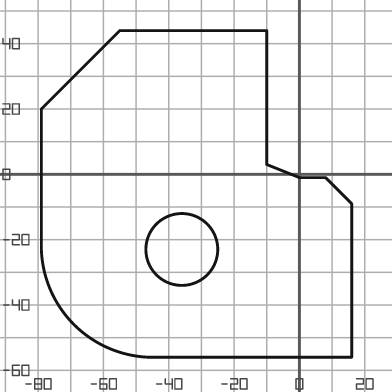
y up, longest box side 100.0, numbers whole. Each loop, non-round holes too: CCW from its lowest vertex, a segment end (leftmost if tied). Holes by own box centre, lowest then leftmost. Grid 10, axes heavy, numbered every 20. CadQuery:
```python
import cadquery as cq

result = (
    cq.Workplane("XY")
    .moveTo(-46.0, -56.0)
    .lineTo(16.0, -56.0)
    .lineTo(16.0, -9.0)
    .lineTo(8.0, -1.0)
    .lineTo(0.0, -1.0)
    .lineTo(-10.0, 3.0)
    .lineTo(-10.0, 44.0)
    .lineTo(-55.0, 44.0)
    .lineTo(-79.0, 20.0)
    .lineTo(-79.0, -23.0)
    .threePointArc((-69.0, -46.0), (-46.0, -56.0))
    .close()
    .moveTo(-36.0, -23.0)
    .circle(11.0)
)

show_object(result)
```